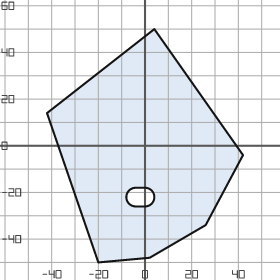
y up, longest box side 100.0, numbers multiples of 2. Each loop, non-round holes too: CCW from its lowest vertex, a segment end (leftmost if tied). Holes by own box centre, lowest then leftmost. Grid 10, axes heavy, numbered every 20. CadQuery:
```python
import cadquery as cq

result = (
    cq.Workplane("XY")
    .moveTo(-20.0, -50.0)
    .lineTo(2.0, -48.0)
    .lineTo(26.0, -34.0)
    .lineTo(42.0, -4.0)
    .lineTo(4.0, 50.0)
    .lineTo(-42.0, 14.0)
    .close()
    .moveTo(-4.0, -26.0)
    .lineTo(0.0, -26.0)
    .threePointArc((4.0, -22.0), (0.0, -18.0))
    .lineTo(-4.0, -18.0)
    .threePointArc((-8.0, -22.0), (-4.0, -26.0))
    .close()
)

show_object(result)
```